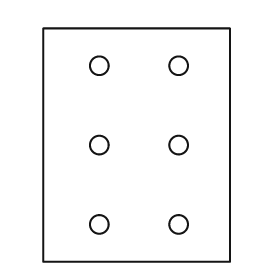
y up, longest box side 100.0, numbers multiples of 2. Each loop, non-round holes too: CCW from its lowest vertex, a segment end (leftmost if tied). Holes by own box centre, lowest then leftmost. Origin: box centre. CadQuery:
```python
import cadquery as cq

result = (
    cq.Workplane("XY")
    .moveTo(-40.0, -50.0)
    .lineTo(40.0, -50.0)
    .lineTo(40.0, 50.0)
    .lineTo(-40.0, 50.0)
    .close()
    .moveTo(-16.0, -34.0)
    .circle(4.0)
    .moveTo(18.0, -34.0)
    .circle(4.0)
    .moveTo(-16.0, 0.0)
    .circle(4.0)
    .moveTo(18.0, 0.0)
    .circle(4.0)
    .moveTo(-16.0, 34.0)
    .circle(4.0)
    .moveTo(18.0, 34.0)
    .circle(4.0)
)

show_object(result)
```